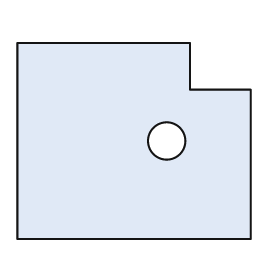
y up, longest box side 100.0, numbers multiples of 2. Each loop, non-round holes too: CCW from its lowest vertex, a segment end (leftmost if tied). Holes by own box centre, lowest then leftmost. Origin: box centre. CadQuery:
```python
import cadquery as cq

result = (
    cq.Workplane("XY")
    .moveTo(-50.0, -42.0)
    .lineTo(50.0, -42.0)
    .lineTo(50.0, 22.0)
    .lineTo(24.0, 22.0)
    .lineTo(24.0, 42.0)
    .lineTo(-50.0, 42.0)
    .close()
    .moveTo(14.0, 0.0)
    .circle(8.0)
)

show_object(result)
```